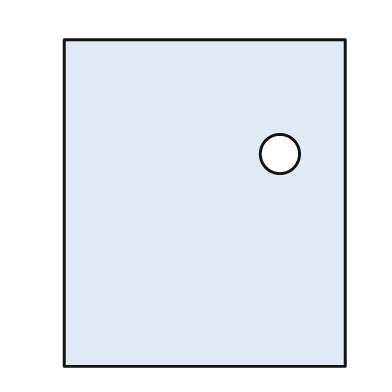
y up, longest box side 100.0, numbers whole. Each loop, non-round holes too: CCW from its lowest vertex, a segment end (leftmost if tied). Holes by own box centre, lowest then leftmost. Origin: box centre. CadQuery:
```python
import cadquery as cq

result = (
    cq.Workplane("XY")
    .moveTo(-43.0, -50.0)
    .lineTo(43.0, -50.0)
    .lineTo(43.0, 50.0)
    .lineTo(-43.0, 50.0)
    .close()
    .moveTo(23.0, 15.0)
    .circle(6.0)
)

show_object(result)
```